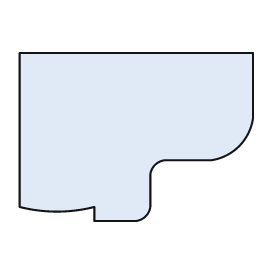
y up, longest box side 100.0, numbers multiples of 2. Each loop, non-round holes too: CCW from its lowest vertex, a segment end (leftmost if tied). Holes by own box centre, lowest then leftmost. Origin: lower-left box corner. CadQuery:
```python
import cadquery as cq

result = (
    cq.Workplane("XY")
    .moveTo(32.0, 0.0)
    .lineTo(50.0, 0.0)
    .threePointArc((54.0, 2.0), (56.0, 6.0))
    .lineTo(56.0, 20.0)
    .threePointArc((58.0, 24.0), (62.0, 26.0))
    .lineTo(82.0, 26.0)
    .threePointArc((94.0, 32.0), (100.0, 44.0))
    .lineTo(100.0, 72.0)
    .lineTo(0.0, 72.0)
    .lineTo(0.0, 6.0)
    .threePointArc((16.0, 4.0), (32.0, 6.0))
    .close()
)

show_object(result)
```